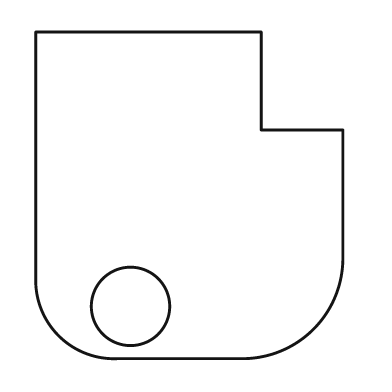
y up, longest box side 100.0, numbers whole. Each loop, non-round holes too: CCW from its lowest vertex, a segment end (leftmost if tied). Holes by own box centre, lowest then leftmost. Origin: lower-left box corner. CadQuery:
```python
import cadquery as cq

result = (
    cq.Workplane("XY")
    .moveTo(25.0, 0.0)
    .lineTo(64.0, 0.0)
    .threePointArc((85.0, 9.0), (94.0, 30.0))
    .lineTo(94.0, 70.0)
    .lineTo(69.0, 70.0)
    .lineTo(69.0, 100.0)
    .lineTo(0.0, 100.0)
    .lineTo(0.0, 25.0)
    .threePointArc((7.0, 7.0), (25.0, 0.0))
    .close()
    .moveTo(29.0, 16.0)
    .circle(12.0)
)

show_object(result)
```